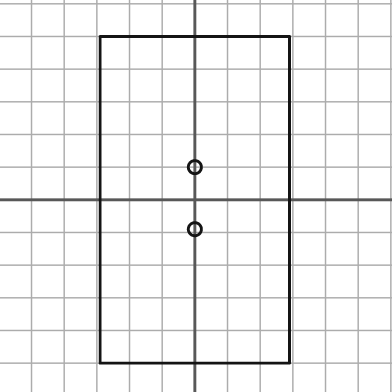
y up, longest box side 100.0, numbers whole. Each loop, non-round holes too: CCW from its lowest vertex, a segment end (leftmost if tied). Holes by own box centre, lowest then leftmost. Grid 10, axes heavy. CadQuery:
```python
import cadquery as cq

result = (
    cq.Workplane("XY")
    .moveTo(-29.0, -50.0)
    .lineTo(29.0, -50.0)
    .lineTo(29.0, 50.0)
    .lineTo(-29.0, 50.0)
    .close()
    .moveTo(0.0, -9.0)
    .circle(2.0)
    .moveTo(0.0, 10.0)
    .circle(2.0)
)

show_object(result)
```